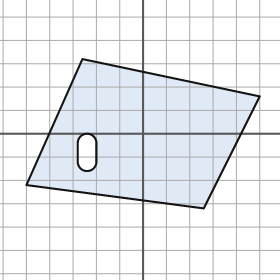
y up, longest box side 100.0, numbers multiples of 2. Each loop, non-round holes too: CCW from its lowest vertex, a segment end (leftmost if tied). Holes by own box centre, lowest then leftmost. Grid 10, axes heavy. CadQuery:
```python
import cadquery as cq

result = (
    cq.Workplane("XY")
    .moveTo(26.0, -32.0)
    .lineTo(50.0, 16.0)
    .lineTo(-26.0, 32.0)
    .lineTo(-50.0, -22.0)
    .close()
    .moveTo(-28.0, -12.0)
    .threePointArc((-24.0, -16.0), (-20.0, -12.0))
    .lineTo(-20.0, -4.0)
    .threePointArc((-24.0, 0.0), (-28.0, -4.0))
    .close()
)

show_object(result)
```